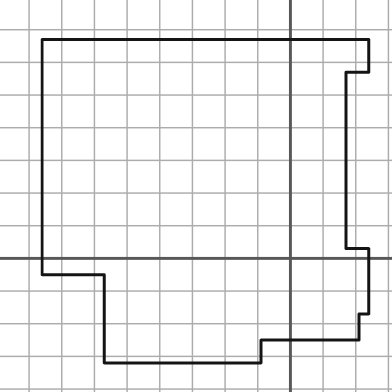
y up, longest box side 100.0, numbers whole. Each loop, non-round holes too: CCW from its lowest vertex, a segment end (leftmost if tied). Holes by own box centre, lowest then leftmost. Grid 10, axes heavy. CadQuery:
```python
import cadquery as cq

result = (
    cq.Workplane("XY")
    .moveTo(-57.0, -32.0)
    .lineTo(-9.0, -32.0)
    .lineTo(-9.0, -25.0)
    .lineTo(21.0, -25.0)
    .lineTo(21.0, -17.0)
    .lineTo(24.0, -17.0)
    .lineTo(24.0, 3.0)
    .lineTo(17.0, 3.0)
    .lineTo(17.0, 57.0)
    .lineTo(24.0, 57.0)
    .lineTo(24.0, 67.0)
    .lineTo(-76.0, 67.0)
    .lineTo(-76.0, -5.0)
    .lineTo(-57.0, -5.0)
    .close()
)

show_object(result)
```